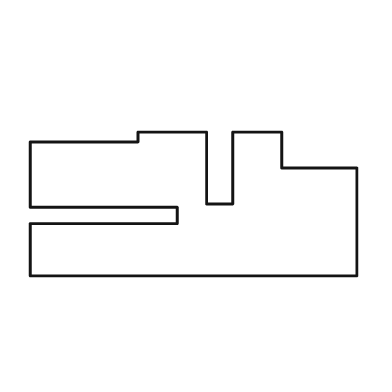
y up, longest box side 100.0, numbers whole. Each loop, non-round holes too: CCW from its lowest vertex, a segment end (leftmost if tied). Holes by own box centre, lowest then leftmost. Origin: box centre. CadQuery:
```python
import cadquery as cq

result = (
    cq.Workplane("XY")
    .moveTo(-50.0, -22.0)
    .lineTo(50.0, -22.0)
    .lineTo(50.0, 11.0)
    .lineTo(27.0, 11.0)
    .lineTo(27.0, 22.0)
    .lineTo(12.0, 22.0)
    .lineTo(12.0, 0.0)
    .lineTo(4.0, 0.0)
    .lineTo(4.0, 22.0)
    .lineTo(-17.0, 22.0)
    .lineTo(-17.0, 19.0)
    .lineTo(-50.0, 19.0)
    .lineTo(-50.0, -1.0)
    .lineTo(-5.0, -1.0)
    .lineTo(-5.0, -6.0)
    .lineTo(-50.0, -6.0)
    .close()
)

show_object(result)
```